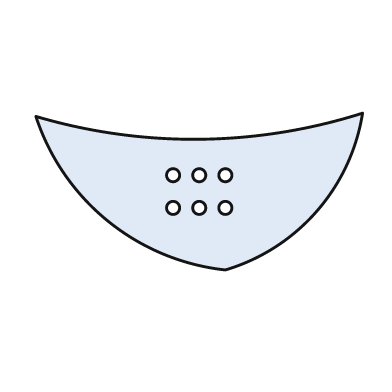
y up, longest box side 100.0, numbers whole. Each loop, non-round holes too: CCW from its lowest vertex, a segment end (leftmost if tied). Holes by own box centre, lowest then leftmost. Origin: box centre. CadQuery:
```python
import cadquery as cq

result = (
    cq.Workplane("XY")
    .moveTo(8.0, -24.0)
    .threePointArc((36.0, -6.0), (50.0, 24.0))
    .threePointArc((0.0, 16.0), (-50.0, 23.0))
    .threePointArc((-28.0, -9.0), (8.0, -24.0))
    .close()
    .moveTo(-8.0, -5.0)
    .circle(2.0)
    .moveTo(0.0, -5.0)
    .circle(2.0)
    .moveTo(8.0, -5.0)
    .circle(2.0)
    .moveTo(-8.0, 5.0)
    .circle(2.0)
    .moveTo(0.0, 5.0)
    .circle(2.0)
    .moveTo(8.0, 5.0)
    .circle(2.0)
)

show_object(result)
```